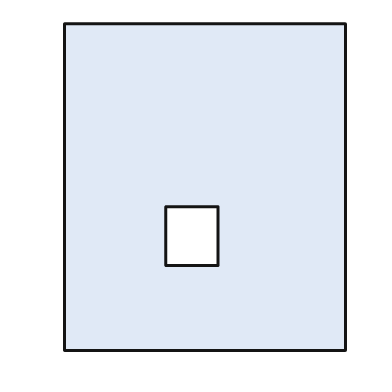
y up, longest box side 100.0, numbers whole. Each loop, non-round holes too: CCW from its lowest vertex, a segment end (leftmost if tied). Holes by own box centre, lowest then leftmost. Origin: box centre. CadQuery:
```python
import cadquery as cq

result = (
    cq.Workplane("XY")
    .moveTo(-43.0, -50.0)
    .lineTo(43.0, -50.0)
    .lineTo(43.0, 50.0)
    .lineTo(-43.0, 50.0)
    .close()
    .moveTo(-12.0, -24.0)
    .lineTo(4.0, -24.0)
    .lineTo(4.0, -6.0)
    .lineTo(-12.0, -6.0)
    .close()
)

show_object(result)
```